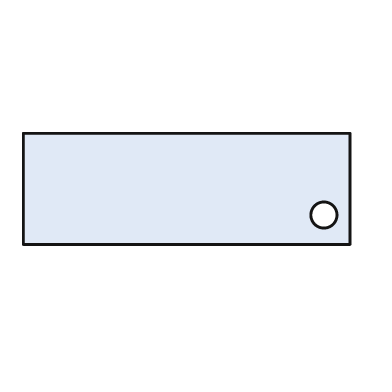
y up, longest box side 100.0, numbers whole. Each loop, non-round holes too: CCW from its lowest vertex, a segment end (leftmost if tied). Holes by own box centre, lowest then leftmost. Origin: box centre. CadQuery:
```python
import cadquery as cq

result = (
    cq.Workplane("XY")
    .moveTo(-50.0, -17.0)
    .lineTo(50.0, -17.0)
    .lineTo(50.0, 17.0)
    .lineTo(-50.0, 17.0)
    .close()
    .moveTo(42.0, -8.0)
    .circle(4.0)
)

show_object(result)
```